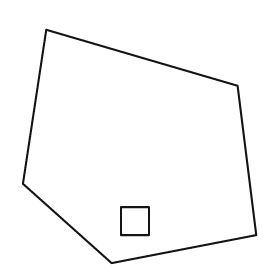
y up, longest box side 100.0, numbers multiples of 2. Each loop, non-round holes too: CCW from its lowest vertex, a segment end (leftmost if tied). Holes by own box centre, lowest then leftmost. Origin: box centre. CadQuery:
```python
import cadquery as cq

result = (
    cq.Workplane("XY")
    .moveTo(-12.0, -50.0)
    .lineTo(50.0, -38.0)
    .lineTo(42.0, 26.0)
    .lineTo(-40.0, 50.0)
    .lineTo(-50.0, -16.0)
    .close()
    .moveTo(-8.0, -38.0)
    .lineTo(4.0, -38.0)
    .lineTo(4.0, -26.0)
    .lineTo(-8.0, -26.0)
    .close()
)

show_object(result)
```